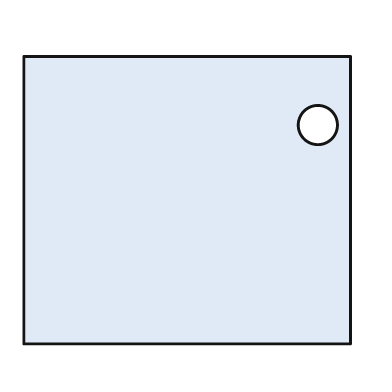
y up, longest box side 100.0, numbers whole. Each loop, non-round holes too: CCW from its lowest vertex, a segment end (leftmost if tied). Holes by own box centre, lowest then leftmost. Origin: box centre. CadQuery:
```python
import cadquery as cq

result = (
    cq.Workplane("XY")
    .moveTo(-50.0, -44.0)
    .lineTo(50.0, -44.0)
    .lineTo(50.0, 44.0)
    .lineTo(-50.0, 44.0)
    .close()
    .moveTo(40.0, 23.0)
    .circle(6.0)
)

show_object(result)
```